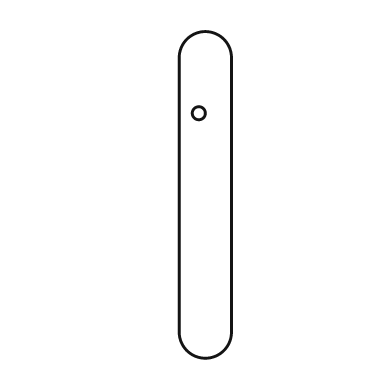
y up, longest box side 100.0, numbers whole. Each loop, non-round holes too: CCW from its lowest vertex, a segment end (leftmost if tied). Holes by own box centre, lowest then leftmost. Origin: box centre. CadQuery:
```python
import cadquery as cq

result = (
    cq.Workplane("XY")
    .moveTo(-8.0, -42.0)
    .threePointArc((0.0, -50.0), (8.0, -42.0))
    .lineTo(8.0, 42.0)
    .threePointArc((0.0, 50.0), (-8.0, 42.0))
    .close()
    .moveTo(-2.0, 25.0)
    .circle(2.0)
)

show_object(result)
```